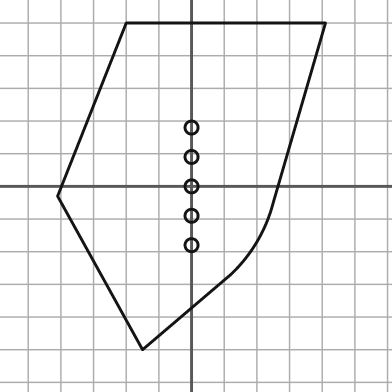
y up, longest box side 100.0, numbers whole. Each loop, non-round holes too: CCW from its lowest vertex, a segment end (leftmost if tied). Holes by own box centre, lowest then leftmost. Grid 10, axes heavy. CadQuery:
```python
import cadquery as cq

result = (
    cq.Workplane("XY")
    .moveTo(-15.0, -50.0)
    .lineTo(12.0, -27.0)
    .threePointArc((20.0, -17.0), (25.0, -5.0))
    .lineTo(41.0, 50.0)
    .lineTo(-20.0, 50.0)
    .lineTo(-41.0, -3.0)
    .close()
    .moveTo(0.0, -18.0)
    .circle(2.0)
    .moveTo(0.0, -9.0)
    .circle(2.0)
    .moveTo(0.0, 0.0)
    .circle(2.0)
    .moveTo(0.0, 9.0)
    .circle(2.0)
    .moveTo(0.0, 18.0)
    .circle(2.0)
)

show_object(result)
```